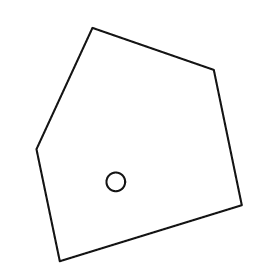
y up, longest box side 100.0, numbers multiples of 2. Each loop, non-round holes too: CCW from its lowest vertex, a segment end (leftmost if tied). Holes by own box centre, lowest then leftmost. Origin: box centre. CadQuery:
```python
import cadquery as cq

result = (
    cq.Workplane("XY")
    .moveTo(-34.0, -50.0)
    .lineTo(44.0, -26.0)
    .lineTo(32.0, 32.0)
    .lineTo(-20.0, 50.0)
    .lineTo(-44.0, -2.0)
    .close()
    .moveTo(-10.0, -16.0)
    .circle(4.0)
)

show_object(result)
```